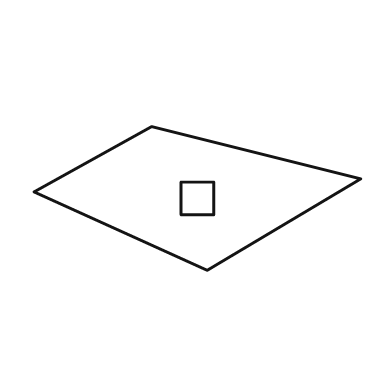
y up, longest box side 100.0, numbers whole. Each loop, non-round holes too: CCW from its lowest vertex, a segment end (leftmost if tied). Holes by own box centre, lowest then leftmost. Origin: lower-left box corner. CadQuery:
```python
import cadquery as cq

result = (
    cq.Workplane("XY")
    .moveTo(53.0, 0.0)
    .lineTo(100.0, 28.0)
    .lineTo(36.0, 44.0)
    .lineTo(0.0, 24.0)
    .close()
    .moveTo(45.0, 17.0)
    .lineTo(55.0, 17.0)
    .lineTo(55.0, 27.0)
    .lineTo(45.0, 27.0)
    .close()
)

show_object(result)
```